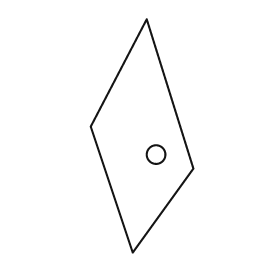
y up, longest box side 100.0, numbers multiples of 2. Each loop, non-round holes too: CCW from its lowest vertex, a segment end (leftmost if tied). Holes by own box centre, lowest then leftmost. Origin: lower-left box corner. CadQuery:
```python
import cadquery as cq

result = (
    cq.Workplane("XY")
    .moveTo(18.0, 0.0)
    .lineTo(44.0, 36.0)
    .lineTo(24.0, 100.0)
    .lineTo(0.0, 54.0)
    .close()
    .moveTo(28.0, 42.0)
    .circle(4.0)
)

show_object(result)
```